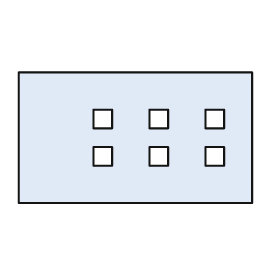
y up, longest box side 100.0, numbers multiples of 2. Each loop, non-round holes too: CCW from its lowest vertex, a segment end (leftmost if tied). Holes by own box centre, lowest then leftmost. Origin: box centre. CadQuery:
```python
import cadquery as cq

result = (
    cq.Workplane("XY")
    .moveTo(-50.0, -28.0)
    .lineTo(50.0, -28.0)
    .lineTo(50.0, 28.0)
    .lineTo(-50.0, 28.0)
    .close()
    .moveTo(-18.0, -12.0)
    .lineTo(-10.0, -12.0)
    .lineTo(-10.0, -4.0)
    .lineTo(-18.0, -4.0)
    .close()
    .moveTo(6.0, -12.0)
    .lineTo(14.0, -12.0)
    .lineTo(14.0, -4.0)
    .lineTo(6.0, -4.0)
    .close()
    .moveTo(30.0, -12.0)
    .lineTo(38.0, -12.0)
    .lineTo(38.0, -4.0)
    .lineTo(30.0, -4.0)
    .close()
    .moveTo(-18.0, 4.0)
    .lineTo(-10.0, 4.0)
    .lineTo(-10.0, 12.0)
    .lineTo(-18.0, 12.0)
    .close()
    .moveTo(6.0, 4.0)
    .lineTo(14.0, 4.0)
    .lineTo(14.0, 12.0)
    .lineTo(6.0, 12.0)
    .close()
    .moveTo(30.0, 4.0)
    .lineTo(38.0, 4.0)
    .lineTo(38.0, 12.0)
    .lineTo(30.0, 12.0)
    .close()
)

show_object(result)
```